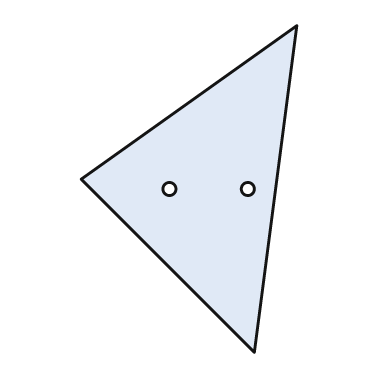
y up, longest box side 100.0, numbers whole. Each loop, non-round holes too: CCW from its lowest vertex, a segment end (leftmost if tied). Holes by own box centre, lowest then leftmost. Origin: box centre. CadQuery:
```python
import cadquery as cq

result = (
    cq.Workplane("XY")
    .moveTo(20.0, -50.0)
    .lineTo(33.0, 50.0)
    .lineTo(-33.0, 3.0)
    .close()
    .moveTo(-6.0, 0.0)
    .circle(2.0)
    .moveTo(18.0, 0.0)
    .circle(2.0)
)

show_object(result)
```